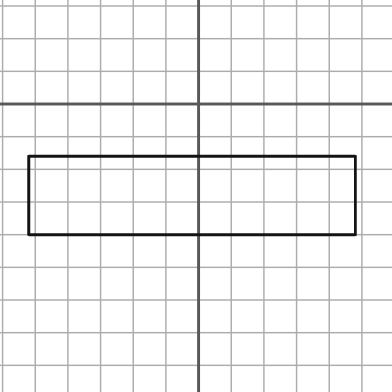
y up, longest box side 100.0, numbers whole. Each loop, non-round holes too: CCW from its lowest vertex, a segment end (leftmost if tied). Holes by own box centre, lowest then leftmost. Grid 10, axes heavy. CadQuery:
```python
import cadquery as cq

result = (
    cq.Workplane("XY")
    .moveTo(-52.0, -40.0)
    .lineTo(48.0, -40.0)
    .lineTo(48.0, -16.0)
    .lineTo(-52.0, -16.0)
    .close()
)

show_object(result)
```